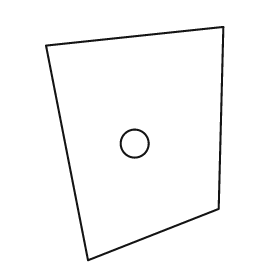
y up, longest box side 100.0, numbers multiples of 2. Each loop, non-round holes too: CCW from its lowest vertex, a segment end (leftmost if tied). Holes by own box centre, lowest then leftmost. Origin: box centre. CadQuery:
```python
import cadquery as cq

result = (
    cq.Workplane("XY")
    .moveTo(-20.0, -50.0)
    .lineTo(36.0, -28.0)
    .lineTo(38.0, 50.0)
    .lineTo(-38.0, 42.0)
    .close()
    .moveTo(0.0, 0.0)
    .circle(6.0)
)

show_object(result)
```